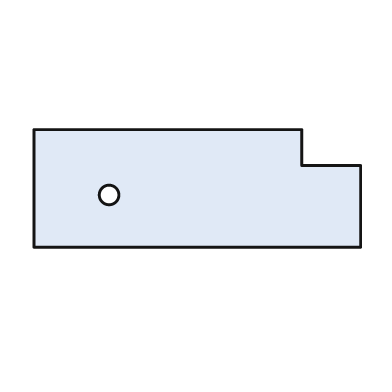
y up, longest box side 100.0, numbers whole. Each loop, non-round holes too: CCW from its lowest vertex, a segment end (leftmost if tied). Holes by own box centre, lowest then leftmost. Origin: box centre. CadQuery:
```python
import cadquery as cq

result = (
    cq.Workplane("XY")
    .moveTo(-50.0, -18.0)
    .lineTo(50.0, -18.0)
    .lineTo(50.0, 7.0)
    .lineTo(32.0, 7.0)
    .lineTo(32.0, 18.0)
    .lineTo(-50.0, 18.0)
    .close()
    .moveTo(-27.0, -2.0)
    .circle(3.0)
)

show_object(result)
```